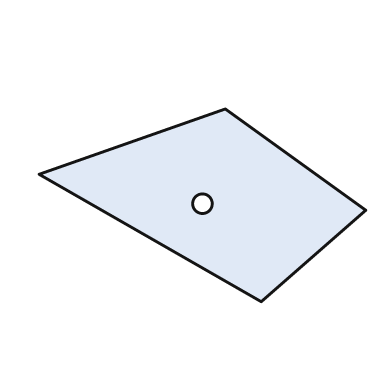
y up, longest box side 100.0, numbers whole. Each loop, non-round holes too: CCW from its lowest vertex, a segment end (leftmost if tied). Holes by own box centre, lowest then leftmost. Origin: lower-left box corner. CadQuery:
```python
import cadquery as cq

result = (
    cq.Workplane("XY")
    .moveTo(68.0, 0.0)
    .lineTo(100.0, 28.0)
    .lineTo(57.0, 59.0)
    .lineTo(0.0, 39.0)
    .close()
    .moveTo(50.0, 30.0)
    .circle(3.0)
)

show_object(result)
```